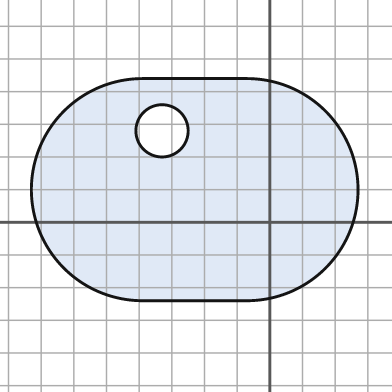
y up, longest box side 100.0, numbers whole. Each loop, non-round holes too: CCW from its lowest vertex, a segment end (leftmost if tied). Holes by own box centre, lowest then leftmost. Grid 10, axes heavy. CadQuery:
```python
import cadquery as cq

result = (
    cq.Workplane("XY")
    .moveTo(-39.0, -24.0)
    .lineTo(-7.0, -24.0)
    .threePointArc((27.0, 10.0), (-7.0, 44.0))
    .lineTo(-39.0, 44.0)
    .threePointArc((-73.0, 10.0), (-39.0, -24.0))
    .close()
    .moveTo(-33.0, 28.0)
    .circle(8.0)
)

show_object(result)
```